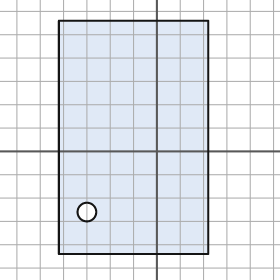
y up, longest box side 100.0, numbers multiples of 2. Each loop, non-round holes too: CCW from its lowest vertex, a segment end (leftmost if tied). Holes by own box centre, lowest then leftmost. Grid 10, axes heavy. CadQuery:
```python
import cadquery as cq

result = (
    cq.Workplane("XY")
    .moveTo(-42.0, -44.0)
    .lineTo(22.0, -44.0)
    .lineTo(22.0, 56.0)
    .lineTo(-42.0, 56.0)
    .close()
    .moveTo(-30.0, -26.0)
    .circle(4.0)
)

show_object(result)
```